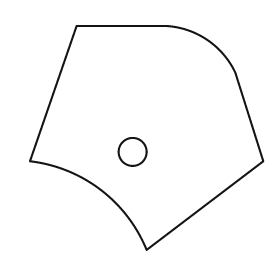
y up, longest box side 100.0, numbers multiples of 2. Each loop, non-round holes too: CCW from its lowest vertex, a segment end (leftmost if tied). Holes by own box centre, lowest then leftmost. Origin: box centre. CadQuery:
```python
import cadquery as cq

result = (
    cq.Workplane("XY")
    .moveTo(0.0, -48.0)
    .lineTo(50.0, -10.0)
    .lineTo(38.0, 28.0)
    .threePointArc((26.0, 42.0), (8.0, 48.0))
    .lineTo(-30.0, 48.0)
    .lineTo(-50.0, -10.0)
    .threePointArc((-20.0, -22.0), (0.0, -48.0))
    .close()
    .moveTo(-6.0, -6.0)
    .circle(6.0)
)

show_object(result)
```